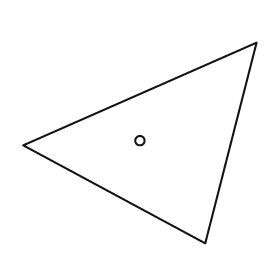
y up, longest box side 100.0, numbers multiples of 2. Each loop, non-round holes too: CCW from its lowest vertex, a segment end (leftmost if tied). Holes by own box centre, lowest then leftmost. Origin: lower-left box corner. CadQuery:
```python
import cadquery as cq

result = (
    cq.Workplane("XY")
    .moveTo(78.0, 0.0)
    .lineTo(100.0, 86.0)
    .lineTo(0.0, 42.0)
    .close()
    .moveTo(50.0, 44.0)
    .circle(2.0)
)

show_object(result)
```